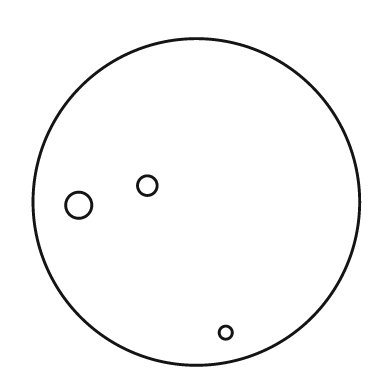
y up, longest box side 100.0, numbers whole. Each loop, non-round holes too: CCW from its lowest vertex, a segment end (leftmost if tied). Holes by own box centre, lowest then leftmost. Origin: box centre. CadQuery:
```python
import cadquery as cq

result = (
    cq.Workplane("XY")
    .moveTo(0.0, 0.0)
    .circle(50.0)
    .moveTo(9.0, -40.0)
    .circle(2.0)
    .moveTo(-36.0, -1.0)
    .circle(4.0)
    .moveTo(-15.0, 5.0)
    .circle(3.0)
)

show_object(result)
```